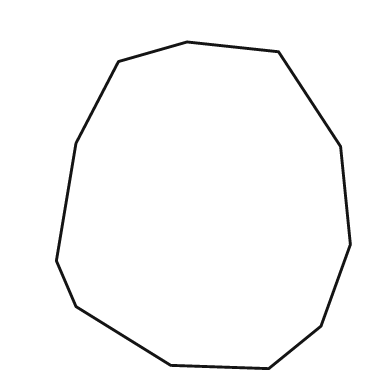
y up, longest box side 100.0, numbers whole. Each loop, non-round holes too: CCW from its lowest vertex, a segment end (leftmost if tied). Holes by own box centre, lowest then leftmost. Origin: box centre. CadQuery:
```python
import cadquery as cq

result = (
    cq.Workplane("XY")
    .moveTo(20.0, -50.0)
    .lineTo(36.0, -37.0)
    .lineTo(45.0, -12.0)
    .lineTo(42.0, 18.0)
    .lineTo(23.0, 47.0)
    .lineTo(-5.0, 50.0)
    .lineTo(-26.0, 44.0)
    .lineTo(-39.0, 19.0)
    .lineTo(-45.0, -17.0)
    .lineTo(-39.0, -31.0)
    .lineTo(-10.0, -49.0)
    .close()
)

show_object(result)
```